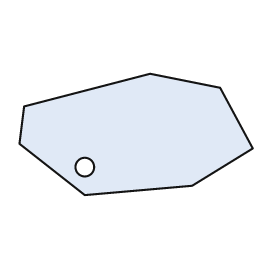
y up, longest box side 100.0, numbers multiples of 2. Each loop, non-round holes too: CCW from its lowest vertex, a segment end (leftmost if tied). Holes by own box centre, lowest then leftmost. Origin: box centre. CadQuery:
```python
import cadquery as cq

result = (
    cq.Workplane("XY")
    .moveTo(-22.0, -26.0)
    .lineTo(24.0, -22.0)
    .lineTo(50.0, -6.0)
    .lineTo(36.0, 20.0)
    .lineTo(6.0, 26.0)
    .lineTo(-48.0, 12.0)
    .lineTo(-50.0, -4.0)
    .close()
    .moveTo(-22.0, -14.0)
    .circle(4.0)
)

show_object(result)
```